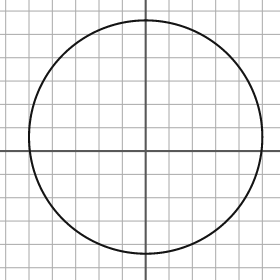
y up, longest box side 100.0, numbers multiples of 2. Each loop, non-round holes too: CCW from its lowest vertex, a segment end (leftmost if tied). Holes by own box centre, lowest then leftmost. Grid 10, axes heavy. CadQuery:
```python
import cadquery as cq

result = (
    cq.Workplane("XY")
    .moveTo(0.0, 6.0)
    .circle(50.0)
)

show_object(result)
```